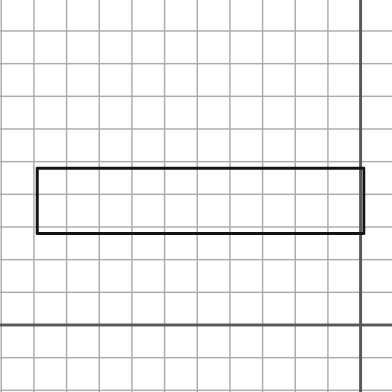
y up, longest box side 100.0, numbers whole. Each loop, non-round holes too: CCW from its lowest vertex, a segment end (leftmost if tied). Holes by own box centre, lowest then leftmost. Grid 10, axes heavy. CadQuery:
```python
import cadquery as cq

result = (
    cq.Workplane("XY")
    .moveTo(-99.0, 28.0)
    .lineTo(1.0, 28.0)
    .lineTo(1.0, 48.0)
    .lineTo(-99.0, 48.0)
    .close()
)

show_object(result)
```